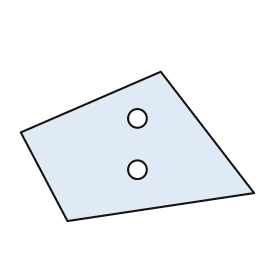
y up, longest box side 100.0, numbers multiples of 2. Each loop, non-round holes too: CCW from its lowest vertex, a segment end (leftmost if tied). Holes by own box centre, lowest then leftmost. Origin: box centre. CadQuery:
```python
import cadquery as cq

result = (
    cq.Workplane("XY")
    .moveTo(-30.0, -32.0)
    .lineTo(50.0, -20.0)
    .lineTo(10.0, 32.0)
    .lineTo(-50.0, 6.0)
    .close()
    .moveTo(0.0, -10.0)
    .circle(4.0)
    .moveTo(0.0, 12.0)
    .circle(4.0)
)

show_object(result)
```